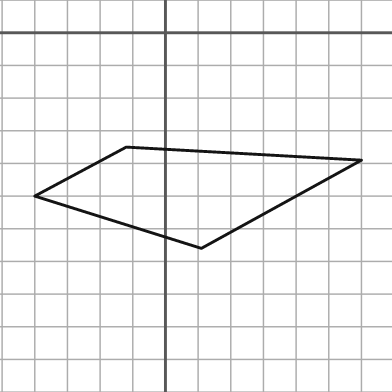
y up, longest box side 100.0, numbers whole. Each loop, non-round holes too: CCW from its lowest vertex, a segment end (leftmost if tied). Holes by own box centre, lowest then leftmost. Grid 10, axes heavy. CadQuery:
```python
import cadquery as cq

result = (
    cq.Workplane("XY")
    .moveTo(11.0, -66.0)
    .lineTo(60.0, -39.0)
    .lineTo(-12.0, -35.0)
    .lineTo(-40.0, -50.0)
    .close()
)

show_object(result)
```